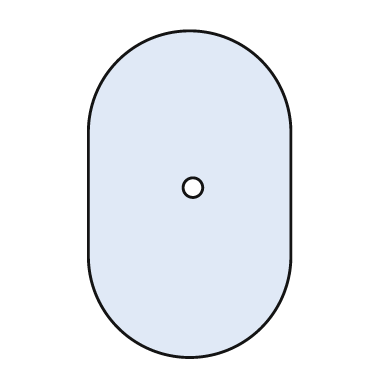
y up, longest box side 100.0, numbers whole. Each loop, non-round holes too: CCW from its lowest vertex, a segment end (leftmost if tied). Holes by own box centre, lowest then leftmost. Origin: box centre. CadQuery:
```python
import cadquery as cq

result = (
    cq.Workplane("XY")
    .moveTo(-31.0, -19.0)
    .threePointArc((0.0, -50.0), (31.0, -19.0))
    .lineTo(31.0, 19.0)
    .threePointArc((0.0, 50.0), (-31.0, 19.0))
    .close()
    .moveTo(1.0, 2.0)
    .circle(3.0)
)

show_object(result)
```